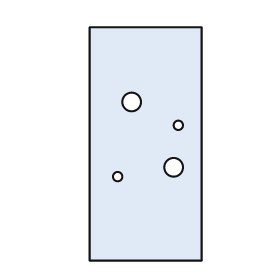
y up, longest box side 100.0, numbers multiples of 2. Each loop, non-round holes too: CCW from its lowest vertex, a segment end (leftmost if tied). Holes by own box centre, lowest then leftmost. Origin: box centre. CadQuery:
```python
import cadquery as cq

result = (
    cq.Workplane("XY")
    .moveTo(-24.0, -50.0)
    .lineTo(24.0, -50.0)
    .lineTo(24.0, 50.0)
    .lineTo(-24.0, 50.0)
    .close()
    .moveTo(-12.0, -14.0)
    .circle(2.0)
    .moveTo(12.0, -10.0)
    .circle(4.0)
    .moveTo(14.0, 8.0)
    .circle(2.0)
    .moveTo(-6.0, 18.0)
    .circle(4.0)
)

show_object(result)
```